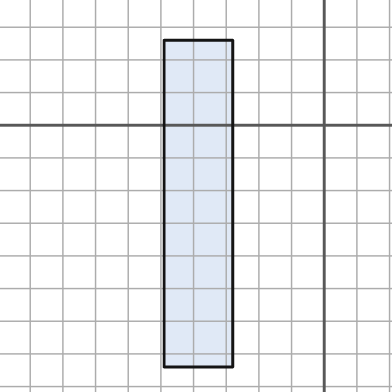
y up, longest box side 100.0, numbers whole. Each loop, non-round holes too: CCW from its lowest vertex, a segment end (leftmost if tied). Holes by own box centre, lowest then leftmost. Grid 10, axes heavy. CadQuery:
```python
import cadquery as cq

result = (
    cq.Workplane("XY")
    .moveTo(-49.0, -74.0)
    .lineTo(-28.0, -74.0)
    .lineTo(-28.0, 26.0)
    .lineTo(-49.0, 26.0)
    .close()
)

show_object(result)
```